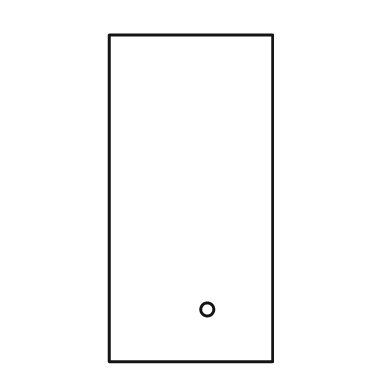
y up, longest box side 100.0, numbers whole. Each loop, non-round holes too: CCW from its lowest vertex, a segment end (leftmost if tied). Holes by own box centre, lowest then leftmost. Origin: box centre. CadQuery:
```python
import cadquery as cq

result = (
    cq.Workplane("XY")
    .moveTo(-25.0, -50.0)
    .lineTo(25.0, -50.0)
    .lineTo(25.0, 50.0)
    .lineTo(-25.0, 50.0)
    .close()
    .moveTo(5.0, -34.0)
    .circle(2.0)
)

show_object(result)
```